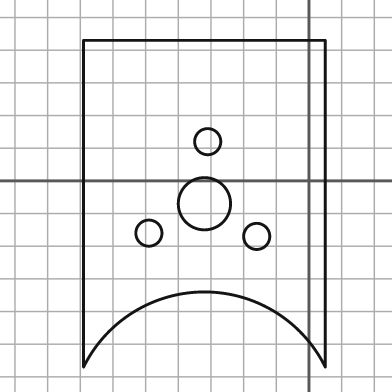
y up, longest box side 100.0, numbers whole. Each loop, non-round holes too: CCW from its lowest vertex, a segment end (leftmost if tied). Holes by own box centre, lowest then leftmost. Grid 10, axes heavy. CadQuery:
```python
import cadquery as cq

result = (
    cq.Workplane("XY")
    .moveTo(-69.0, -57.0)
    .threePointArc((-32.0, -34.0), (5.0, -57.0))
    .lineTo(5.0, 43.0)
    .lineTo(-69.0, 43.0)
    .close()
    .moveTo(-16.0, -17.0)
    .circle(4.0)
    .moveTo(-49.0, -16.0)
    .circle(4.0)
    .moveTo(-32.0, -7.0)
    .circle(8.0)
    .moveTo(-31.0, 12.0)
    .circle(4.0)
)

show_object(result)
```